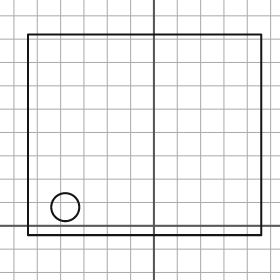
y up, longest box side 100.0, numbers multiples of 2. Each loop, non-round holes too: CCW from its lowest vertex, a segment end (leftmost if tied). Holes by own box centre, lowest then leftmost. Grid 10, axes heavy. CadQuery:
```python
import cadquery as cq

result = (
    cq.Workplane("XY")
    .moveTo(-54.0, -4.0)
    .lineTo(46.0, -4.0)
    .lineTo(46.0, 82.0)
    .lineTo(-54.0, 82.0)
    .close()
    .moveTo(-38.0, 8.0)
    .circle(6.0)
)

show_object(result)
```